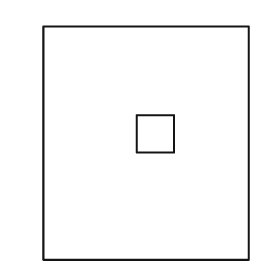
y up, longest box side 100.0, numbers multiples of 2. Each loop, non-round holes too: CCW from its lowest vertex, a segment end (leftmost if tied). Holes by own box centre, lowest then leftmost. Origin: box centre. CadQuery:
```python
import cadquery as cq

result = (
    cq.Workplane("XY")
    .moveTo(-44.0, -50.0)
    .lineTo(44.0, -50.0)
    .lineTo(44.0, 50.0)
    .lineTo(-44.0, 50.0)
    .close()
    .moveTo(-4.0, -4.0)
    .lineTo(12.0, -4.0)
    .lineTo(12.0, 12.0)
    .lineTo(-4.0, 12.0)
    .close()
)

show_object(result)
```